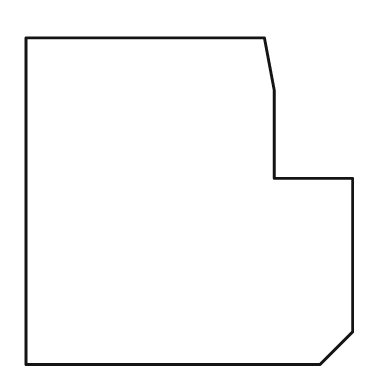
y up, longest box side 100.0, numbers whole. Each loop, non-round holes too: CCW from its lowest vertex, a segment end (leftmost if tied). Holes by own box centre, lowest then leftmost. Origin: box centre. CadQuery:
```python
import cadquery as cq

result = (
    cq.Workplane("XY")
    .moveTo(-50.0, -50.0)
    .lineTo(40.0, -50.0)
    .lineTo(50.0, -40.0)
    .lineTo(50.0, 7.0)
    .lineTo(26.0, 7.0)
    .lineTo(26.0, 34.0)
    .lineTo(23.0, 50.0)
    .lineTo(-50.0, 50.0)
    .close()
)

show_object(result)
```